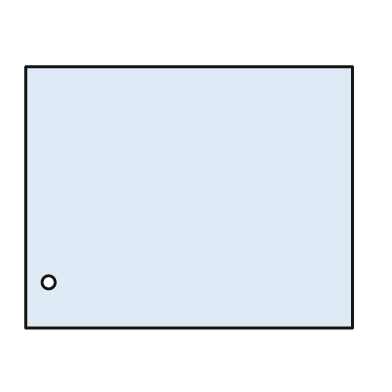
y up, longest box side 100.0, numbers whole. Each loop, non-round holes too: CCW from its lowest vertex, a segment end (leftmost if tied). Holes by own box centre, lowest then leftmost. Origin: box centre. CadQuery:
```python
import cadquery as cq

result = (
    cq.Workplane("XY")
    .moveTo(-50.0, -40.0)
    .lineTo(50.0, -40.0)
    .lineTo(50.0, 40.0)
    .lineTo(-50.0, 40.0)
    .close()
    .moveTo(-43.0, -26.0)
    .circle(2.0)
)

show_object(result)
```